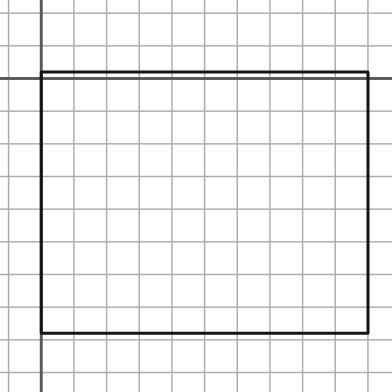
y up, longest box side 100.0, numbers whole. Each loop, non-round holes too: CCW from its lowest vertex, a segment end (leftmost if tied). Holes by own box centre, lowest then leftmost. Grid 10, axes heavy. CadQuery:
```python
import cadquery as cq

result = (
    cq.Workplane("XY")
    .moveTo(0.0, -78.0)
    .lineTo(100.0, -78.0)
    .lineTo(100.0, 2.0)
    .lineTo(0.0, 2.0)
    .close()
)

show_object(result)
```